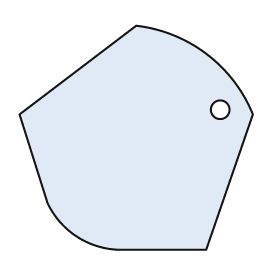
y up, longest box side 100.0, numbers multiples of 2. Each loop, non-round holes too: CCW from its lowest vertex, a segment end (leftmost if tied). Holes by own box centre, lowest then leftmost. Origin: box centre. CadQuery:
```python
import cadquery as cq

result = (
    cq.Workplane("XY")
    .moveTo(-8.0, -48.0)
    .lineTo(30.0, -48.0)
    .lineTo(50.0, 10.0)
    .threePointArc((30.0, 36.0), (0.0, 48.0))
    .lineTo(-50.0, 10.0)
    .lineTo(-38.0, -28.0)
    .threePointArc((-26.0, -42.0), (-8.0, -48.0))
    .close()
    .moveTo(36.0, 12.0)
    .circle(4.0)
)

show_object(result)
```